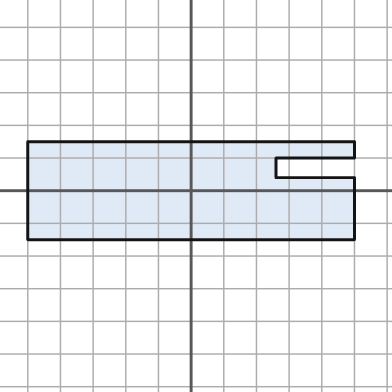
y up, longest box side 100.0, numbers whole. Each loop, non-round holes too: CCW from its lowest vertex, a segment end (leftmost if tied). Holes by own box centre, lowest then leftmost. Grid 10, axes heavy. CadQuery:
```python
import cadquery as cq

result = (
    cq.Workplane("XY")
    .moveTo(-50.0, -15.0)
    .lineTo(50.0, -15.0)
    .lineTo(50.0, 4.0)
    .lineTo(26.0, 4.0)
    .lineTo(26.0, 10.0)
    .lineTo(50.0, 10.0)
    .lineTo(50.0, 15.0)
    .lineTo(-50.0, 15.0)
    .close()
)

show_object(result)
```